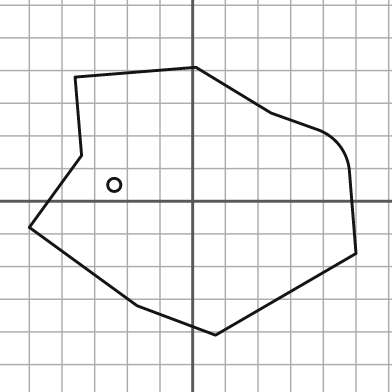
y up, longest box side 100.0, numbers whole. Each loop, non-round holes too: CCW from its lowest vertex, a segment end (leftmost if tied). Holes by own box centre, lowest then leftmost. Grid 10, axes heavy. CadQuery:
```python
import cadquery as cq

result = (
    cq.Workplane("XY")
    .moveTo(7.0, -41.0)
    .lineTo(50.0, -16.0)
    .lineTo(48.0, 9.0)
    .threePointArc((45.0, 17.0), (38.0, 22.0))
    .lineTo(24.0, 27.0)
    .lineTo(1.0, 41.0)
    .lineTo(-36.0, 38.0)
    .lineTo(-34.0, 14.0)
    .lineTo(-50.0, -8.0)
    .lineTo(-17.0, -32.0)
    .close()
    .moveTo(-24.0, 5.0)
    .circle(2.0)
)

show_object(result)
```